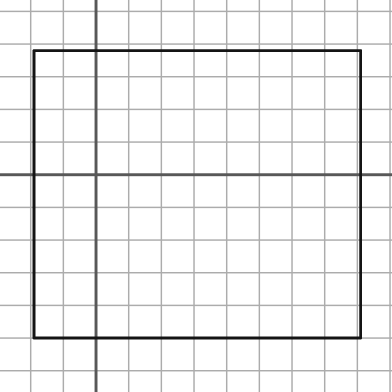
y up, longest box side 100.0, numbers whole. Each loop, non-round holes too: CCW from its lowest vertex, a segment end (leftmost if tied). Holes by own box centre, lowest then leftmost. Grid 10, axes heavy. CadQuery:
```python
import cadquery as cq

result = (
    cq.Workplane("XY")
    .moveTo(-19.0, -50.0)
    .lineTo(81.0, -50.0)
    .lineTo(81.0, 38.0)
    .lineTo(-19.0, 38.0)
    .close()
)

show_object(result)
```